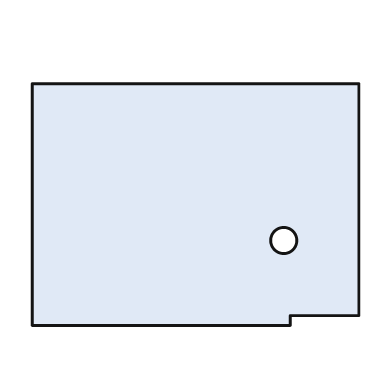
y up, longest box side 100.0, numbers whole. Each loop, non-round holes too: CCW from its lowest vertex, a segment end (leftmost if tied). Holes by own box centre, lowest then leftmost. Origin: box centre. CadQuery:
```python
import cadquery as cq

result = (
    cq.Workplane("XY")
    .moveTo(-50.0, -37.0)
    .lineTo(29.0, -37.0)
    .lineTo(29.0, -34.0)
    .lineTo(50.0, -34.0)
    .lineTo(50.0, 37.0)
    .lineTo(-50.0, 37.0)
    .close()
    .moveTo(27.0, -11.0)
    .circle(4.0)
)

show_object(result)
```